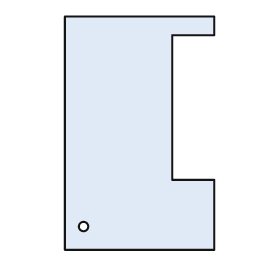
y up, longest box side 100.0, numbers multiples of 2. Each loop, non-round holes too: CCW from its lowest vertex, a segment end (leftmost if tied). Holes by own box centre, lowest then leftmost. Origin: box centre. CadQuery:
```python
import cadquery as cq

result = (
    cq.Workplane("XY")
    .moveTo(-32.0, -50.0)
    .lineTo(32.0, -50.0)
    .lineTo(32.0, -20.0)
    .lineTo(14.0, -20.0)
    .lineTo(14.0, 42.0)
    .lineTo(32.0, 42.0)
    .lineTo(32.0, 50.0)
    .lineTo(-32.0, 50.0)
    .close()
    .moveTo(-24.0, -40.0)
    .circle(2.0)
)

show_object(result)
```